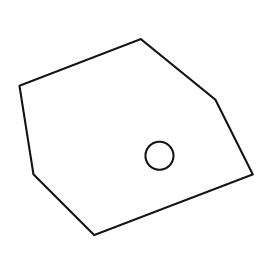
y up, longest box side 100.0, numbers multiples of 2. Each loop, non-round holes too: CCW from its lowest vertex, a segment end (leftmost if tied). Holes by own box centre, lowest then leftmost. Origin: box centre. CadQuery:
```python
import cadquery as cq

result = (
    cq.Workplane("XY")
    .moveTo(-18.0, -42.0)
    .lineTo(50.0, -16.0)
    .lineTo(34.0, 16.0)
    .lineTo(2.0, 42.0)
    .lineTo(-50.0, 22.0)
    .lineTo(-44.0, -16.0)
    .close()
    .moveTo(10.0, -8.0)
    .circle(6.0)
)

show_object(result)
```